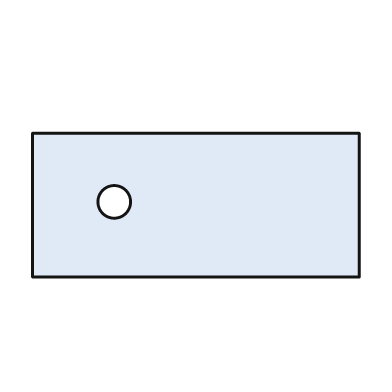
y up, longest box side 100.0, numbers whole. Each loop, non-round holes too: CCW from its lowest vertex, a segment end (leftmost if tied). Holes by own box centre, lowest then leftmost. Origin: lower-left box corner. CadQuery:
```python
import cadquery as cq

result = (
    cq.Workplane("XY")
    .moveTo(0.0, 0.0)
    .lineTo(100.0, 0.0)
    .lineTo(100.0, 44.0)
    .lineTo(0.0, 44.0)
    .close()
    .moveTo(25.0, 23.0)
    .circle(5.0)
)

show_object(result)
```